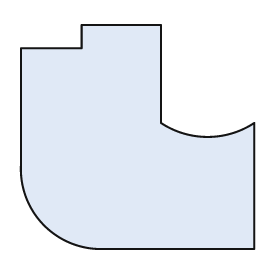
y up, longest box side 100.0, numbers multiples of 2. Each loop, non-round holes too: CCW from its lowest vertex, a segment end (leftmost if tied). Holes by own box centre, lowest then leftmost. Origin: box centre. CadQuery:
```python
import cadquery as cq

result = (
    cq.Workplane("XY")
    .moveTo(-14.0, -48.0)
    .lineTo(50.0, -48.0)
    .lineTo(50.0, 6.0)
    .threePointArc((30.0, 0.0), (10.0, 6.0))
    .lineTo(10.0, 48.0)
    .lineTo(-24.0, 48.0)
    .lineTo(-24.0, 38.0)
    .lineTo(-50.0, 38.0)
    .lineTo(-50.0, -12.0)
    .threePointArc((-40.0, -38.0), (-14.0, -48.0))
    .close()
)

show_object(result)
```